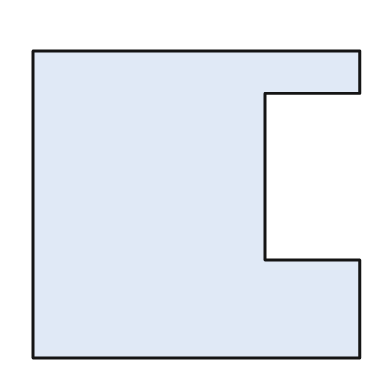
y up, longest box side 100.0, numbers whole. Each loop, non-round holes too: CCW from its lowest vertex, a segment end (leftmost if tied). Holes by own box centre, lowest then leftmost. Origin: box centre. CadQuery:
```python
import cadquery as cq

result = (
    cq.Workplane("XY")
    .moveTo(-50.0, -47.0)
    .lineTo(50.0, -47.0)
    .lineTo(50.0, -17.0)
    .lineTo(21.0, -17.0)
    .lineTo(21.0, 34.0)
    .lineTo(50.0, 34.0)
    .lineTo(50.0, 47.0)
    .lineTo(-50.0, 47.0)
    .close()
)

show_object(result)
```